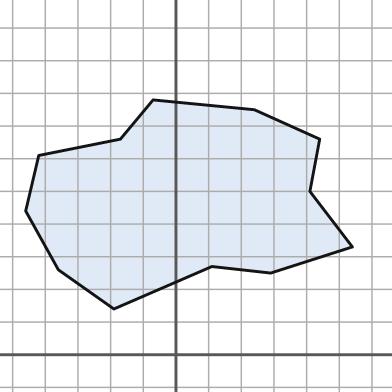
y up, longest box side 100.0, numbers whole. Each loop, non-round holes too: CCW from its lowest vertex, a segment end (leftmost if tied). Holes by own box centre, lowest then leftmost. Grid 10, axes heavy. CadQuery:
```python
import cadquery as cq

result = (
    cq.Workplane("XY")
    .moveTo(-19.0, 14.0)
    .lineTo(11.0, 27.0)
    .lineTo(29.0, 25.0)
    .lineTo(54.0, 33.0)
    .lineTo(41.0, 50.0)
    .lineTo(44.0, 66.0)
    .lineTo(24.0, 75.0)
    .lineTo(-7.0, 78.0)
    .lineTo(-17.0, 66.0)
    .lineTo(-42.0, 61.0)
    .lineTo(-46.0, 44.0)
    .lineTo(-36.0, 26.0)
    .close()
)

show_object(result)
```